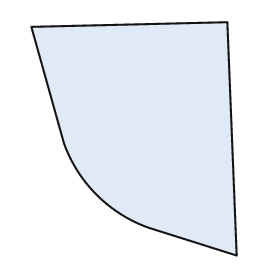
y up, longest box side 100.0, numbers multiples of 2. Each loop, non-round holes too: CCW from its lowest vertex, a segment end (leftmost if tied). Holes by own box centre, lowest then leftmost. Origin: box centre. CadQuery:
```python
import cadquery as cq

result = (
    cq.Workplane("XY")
    .moveTo(44.0, -50.0)
    .lineTo(40.0, 50.0)
    .lineTo(-44.0, 48.0)
    .lineTo(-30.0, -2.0)
    .threePointArc((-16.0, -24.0), (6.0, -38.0))
    .close()
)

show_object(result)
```